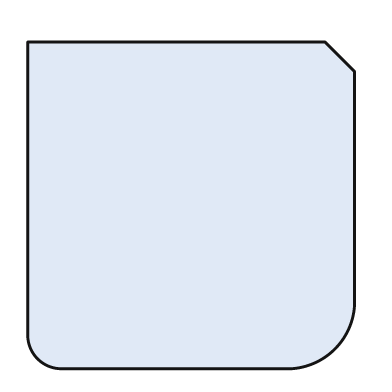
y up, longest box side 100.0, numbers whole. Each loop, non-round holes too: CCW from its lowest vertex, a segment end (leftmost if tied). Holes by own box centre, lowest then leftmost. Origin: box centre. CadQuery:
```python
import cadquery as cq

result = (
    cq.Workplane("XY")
    .moveTo(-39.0, -50.0)
    .lineTo(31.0, -50.0)
    .threePointArc((44.0, -44.0), (50.0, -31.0))
    .lineTo(50.0, 41.0)
    .lineTo(41.0, 50.0)
    .lineTo(-50.0, 50.0)
    .lineTo(-50.0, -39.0)
    .threePointArc((-47.0, -47.0), (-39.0, -50.0))
    .close()
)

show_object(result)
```